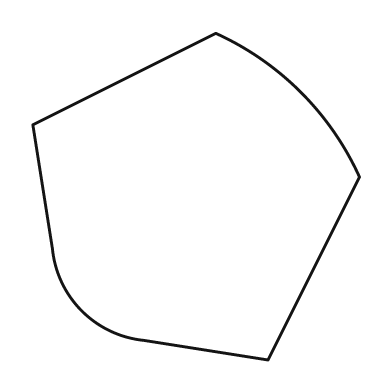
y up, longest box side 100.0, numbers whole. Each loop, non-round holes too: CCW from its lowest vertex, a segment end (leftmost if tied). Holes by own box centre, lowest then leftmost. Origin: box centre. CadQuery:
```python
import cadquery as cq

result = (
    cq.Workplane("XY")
    .moveTo(22.0, -50.0)
    .lineTo(50.0, 6.0)
    .threePointArc((32.0, 32.0), (6.0, 50.0))
    .lineTo(-50.0, 22.0)
    .lineTo(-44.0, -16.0)
    .threePointArc((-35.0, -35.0), (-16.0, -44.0))
    .close()
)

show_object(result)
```